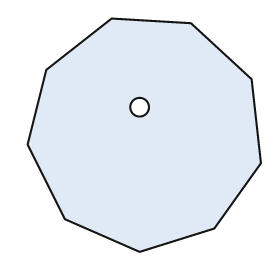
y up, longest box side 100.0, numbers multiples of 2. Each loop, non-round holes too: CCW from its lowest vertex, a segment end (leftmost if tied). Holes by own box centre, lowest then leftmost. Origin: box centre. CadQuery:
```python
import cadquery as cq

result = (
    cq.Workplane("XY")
    .moveTo(-2.0, -50.0)
    .lineTo(30.0, -40.0)
    .lineTo(50.0, -12.0)
    .lineTo(46.0, 24.0)
    .lineTo(20.0, 48.0)
    .lineTo(-14.0, 50.0)
    .lineTo(-42.0, 28.0)
    .lineTo(-50.0, -4.0)
    .lineTo(-34.0, -36.0)
    .close()
    .moveTo(-2.0, 12.0)
    .circle(4.0)
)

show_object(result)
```